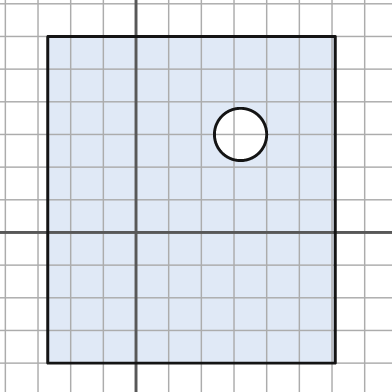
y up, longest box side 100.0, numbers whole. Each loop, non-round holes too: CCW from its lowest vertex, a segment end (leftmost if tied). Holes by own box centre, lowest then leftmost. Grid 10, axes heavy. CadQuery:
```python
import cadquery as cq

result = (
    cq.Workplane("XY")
    .moveTo(-27.0, -40.0)
    .lineTo(61.0, -40.0)
    .lineTo(61.0, 60.0)
    .lineTo(-27.0, 60.0)
    .close()
    .moveTo(32.0, 30.0)
    .circle(8.0)
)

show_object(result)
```